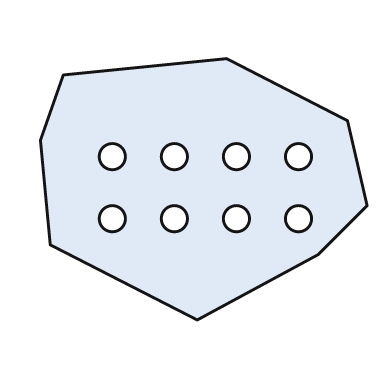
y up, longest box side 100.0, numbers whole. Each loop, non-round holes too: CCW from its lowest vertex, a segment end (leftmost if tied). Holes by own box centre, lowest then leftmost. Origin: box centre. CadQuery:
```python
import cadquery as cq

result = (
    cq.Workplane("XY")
    .moveTo(-2.0, -40.0)
    .lineTo(35.0, -20.0)
    .lineTo(50.0, -5.0)
    .lineTo(44.0, 21.0)
    .lineTo(7.0, 40.0)
    .lineTo(-43.0, 35.0)
    .lineTo(-50.0, 15.0)
    .lineTo(-47.0, -17.0)
    .close()
    .moveTo(-28.0, -9.0)
    .circle(4.0)
    .moveTo(-9.0, -9.0)
    .circle(4.0)
    .moveTo(10.0, -9.0)
    .circle(4.0)
    .moveTo(29.0, -9.0)
    .circle(4.0)
    .moveTo(-28.0, 10.0)
    .circle(4.0)
    .moveTo(-9.0, 10.0)
    .circle(4.0)
    .moveTo(10.0, 10.0)
    .circle(4.0)
    .moveTo(29.0, 10.0)
    .circle(4.0)
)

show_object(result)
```